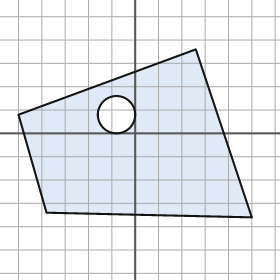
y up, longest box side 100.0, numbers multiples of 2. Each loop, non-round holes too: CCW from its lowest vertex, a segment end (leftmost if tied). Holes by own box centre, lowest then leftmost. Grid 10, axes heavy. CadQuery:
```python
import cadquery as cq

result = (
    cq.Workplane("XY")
    .moveTo(50.0, -36.0)
    .lineTo(26.0, 36.0)
    .lineTo(-50.0, 8.0)
    .lineTo(-38.0, -34.0)
    .close()
    .moveTo(-8.0, 8.0)
    .circle(8.0)
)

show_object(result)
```